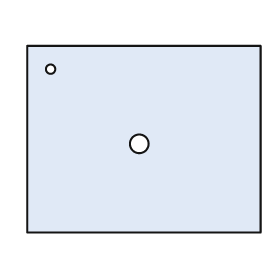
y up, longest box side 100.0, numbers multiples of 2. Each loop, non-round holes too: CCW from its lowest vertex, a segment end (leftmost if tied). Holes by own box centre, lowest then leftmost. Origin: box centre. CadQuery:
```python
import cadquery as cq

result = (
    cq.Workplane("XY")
    .moveTo(-50.0, -40.0)
    .lineTo(50.0, -40.0)
    .lineTo(50.0, 40.0)
    .lineTo(-50.0, 40.0)
    .close()
    .moveTo(-2.0, -2.0)
    .circle(4.0)
    .moveTo(-40.0, 30.0)
    .circle(2.0)
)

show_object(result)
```